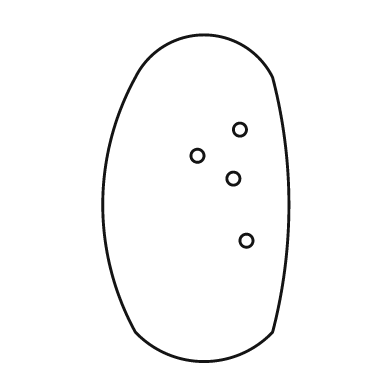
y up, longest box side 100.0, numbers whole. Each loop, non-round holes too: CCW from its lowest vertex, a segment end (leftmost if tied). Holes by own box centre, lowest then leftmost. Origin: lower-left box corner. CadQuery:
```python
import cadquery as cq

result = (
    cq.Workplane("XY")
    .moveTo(10.0, 9.0)
    .threePointArc((31.0, 0.0), (52.0, 9.0))
    .threePointArc((57.0, 48.0), (52.0, 87.0))
    .threePointArc((31.0, 100.0), (10.0, 87.0))
    .threePointArc((0.0, 48.0), (10.0, 9.0))
    .close()
    .moveTo(44.0, 37.0)
    .circle(2.0)
    .moveTo(40.0, 56.0)
    .circle(2.0)
    .moveTo(29.0, 63.0)
    .circle(2.0)
    .moveTo(42.0, 71.0)
    .circle(2.0)
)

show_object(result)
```